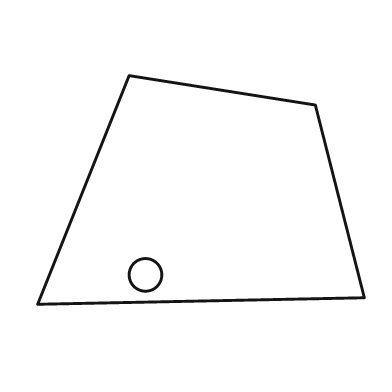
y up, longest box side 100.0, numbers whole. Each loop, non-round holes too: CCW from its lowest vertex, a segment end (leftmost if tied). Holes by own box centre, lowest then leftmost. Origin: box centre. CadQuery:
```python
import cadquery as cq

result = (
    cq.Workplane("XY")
    .moveTo(-50.0, -35.0)
    .lineTo(50.0, -33.0)
    .lineTo(35.0, 26.0)
    .lineTo(-22.0, 35.0)
    .close()
    .moveTo(-17.0, -26.0)
    .circle(5.0)
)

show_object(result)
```